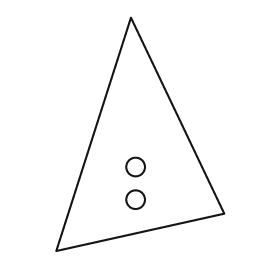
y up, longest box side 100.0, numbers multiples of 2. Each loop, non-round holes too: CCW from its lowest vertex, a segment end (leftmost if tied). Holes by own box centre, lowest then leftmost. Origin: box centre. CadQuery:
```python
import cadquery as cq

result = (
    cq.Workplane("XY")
    .moveTo(-36.0, -50.0)
    .lineTo(36.0, -34.0)
    .lineTo(-4.0, 50.0)
    .close()
    .moveTo(-2.0, -28.0)
    .circle(4.0)
    .moveTo(-2.0, -14.0)
    .circle(4.0)
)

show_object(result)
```